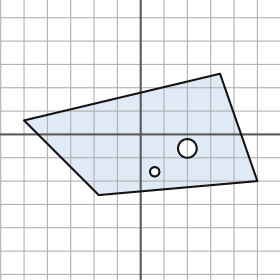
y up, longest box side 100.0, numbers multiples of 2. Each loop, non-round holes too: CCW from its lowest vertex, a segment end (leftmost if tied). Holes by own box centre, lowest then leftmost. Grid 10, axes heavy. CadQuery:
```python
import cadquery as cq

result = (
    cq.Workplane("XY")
    .moveTo(-18.0, -26.0)
    .lineTo(50.0, -20.0)
    .lineTo(34.0, 26.0)
    .lineTo(-50.0, 6.0)
    .close()
    .moveTo(6.0, -16.0)
    .circle(2.0)
    .moveTo(20.0, -6.0)
    .circle(4.0)
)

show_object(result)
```